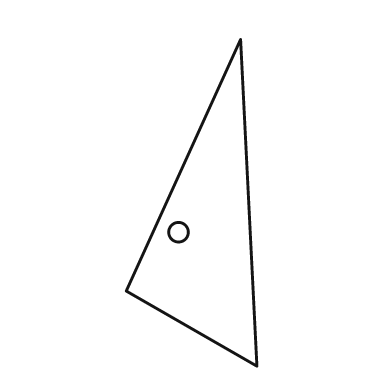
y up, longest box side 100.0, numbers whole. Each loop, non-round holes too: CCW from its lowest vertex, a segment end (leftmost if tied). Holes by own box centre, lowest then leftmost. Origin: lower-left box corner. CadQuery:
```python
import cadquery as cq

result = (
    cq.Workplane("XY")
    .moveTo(40.0, 0.0)
    .lineTo(35.0, 100.0)
    .lineTo(0.0, 23.0)
    .close()
    .moveTo(16.0, 41.0)
    .circle(3.0)
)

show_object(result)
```